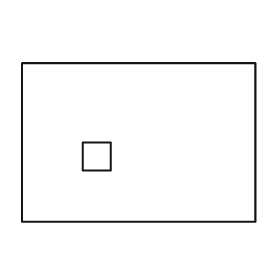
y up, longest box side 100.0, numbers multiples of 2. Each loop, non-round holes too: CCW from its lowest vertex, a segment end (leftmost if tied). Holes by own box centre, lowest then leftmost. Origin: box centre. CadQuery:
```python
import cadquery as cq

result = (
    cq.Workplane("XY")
    .moveTo(-50.0, -34.0)
    .lineTo(50.0, -34.0)
    .lineTo(50.0, 34.0)
    .lineTo(-50.0, 34.0)
    .close()
    .moveTo(-24.0, -12.0)
    .lineTo(-12.0, -12.0)
    .lineTo(-12.0, 0.0)
    .lineTo(-24.0, 0.0)
    .close()
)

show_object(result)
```